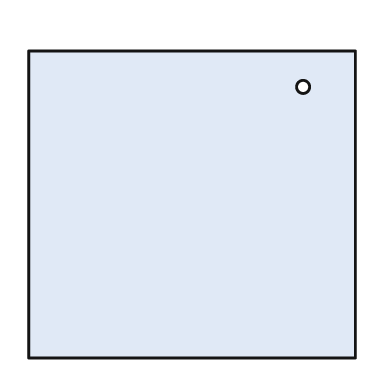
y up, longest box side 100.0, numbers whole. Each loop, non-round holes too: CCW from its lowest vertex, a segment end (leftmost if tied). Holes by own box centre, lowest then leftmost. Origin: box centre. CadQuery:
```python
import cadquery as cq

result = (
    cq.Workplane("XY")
    .moveTo(-50.0, -47.0)
    .lineTo(50.0, -47.0)
    .lineTo(50.0, 47.0)
    .lineTo(-50.0, 47.0)
    .close()
    .moveTo(34.0, 36.0)
    .circle(2.0)
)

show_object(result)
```